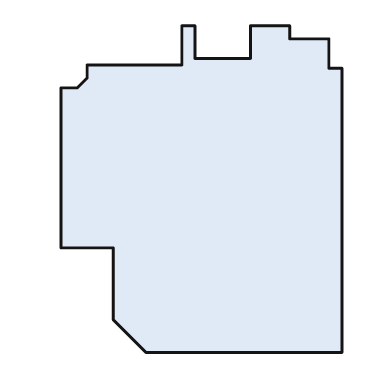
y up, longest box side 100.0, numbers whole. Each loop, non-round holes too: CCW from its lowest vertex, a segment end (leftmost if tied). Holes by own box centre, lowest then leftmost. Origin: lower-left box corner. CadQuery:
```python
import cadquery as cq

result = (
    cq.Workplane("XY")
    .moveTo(26.0, 0.0)
    .lineTo(86.0, 0.0)
    .lineTo(86.0, 87.0)
    .lineTo(82.0, 87.0)
    .lineTo(82.0, 96.0)
    .lineTo(70.0, 96.0)
    .lineTo(70.0, 100.0)
    .lineTo(58.0, 100.0)
    .lineTo(58.0, 90.0)
    .lineTo(41.0, 90.0)
    .lineTo(41.0, 100.0)
    .lineTo(37.0, 100.0)
    .lineTo(37.0, 88.0)
    .lineTo(8.0, 88.0)
    .lineTo(8.0, 84.0)
    .lineTo(5.0, 81.0)
    .lineTo(0.0, 81.0)
    .lineTo(0.0, 32.0)
    .lineTo(16.0, 32.0)
    .lineTo(16.0, 10.0)
    .close()
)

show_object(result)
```